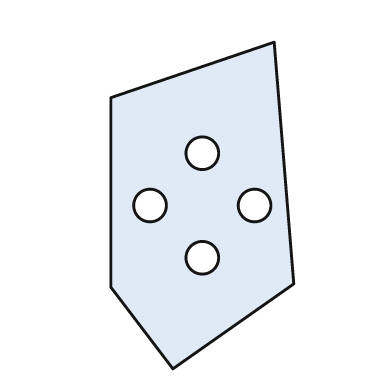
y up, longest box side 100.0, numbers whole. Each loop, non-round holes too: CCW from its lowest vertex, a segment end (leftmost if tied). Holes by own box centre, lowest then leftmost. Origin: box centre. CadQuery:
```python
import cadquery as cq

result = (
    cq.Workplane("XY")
    .moveTo(-9.0, -50.0)
    .lineTo(28.0, -24.0)
    .lineTo(22.0, 50.0)
    .lineTo(-28.0, 33.0)
    .lineTo(-28.0, -25.0)
    .close()
    .moveTo(0.0, -16.0)
    .circle(5.0)
    .moveTo(-16.0, 0.0)
    .circle(5.0)
    .moveTo(16.0, 0.0)
    .circle(5.0)
    .moveTo(0.0, 16.0)
    .circle(5.0)
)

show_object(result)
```